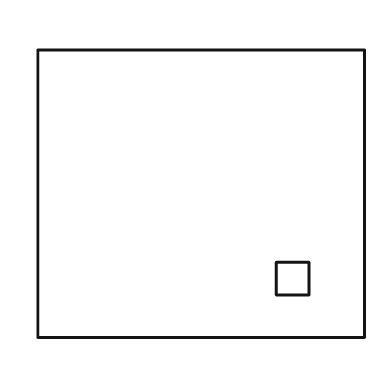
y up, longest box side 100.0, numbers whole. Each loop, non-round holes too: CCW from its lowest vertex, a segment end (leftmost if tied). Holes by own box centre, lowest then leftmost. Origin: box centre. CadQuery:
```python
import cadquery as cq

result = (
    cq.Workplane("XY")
    .moveTo(-50.0, -44.0)
    .lineTo(50.0, -44.0)
    .lineTo(50.0, 44.0)
    .lineTo(-50.0, 44.0)
    .close()
    .moveTo(23.0, -31.0)
    .lineTo(33.0, -31.0)
    .lineTo(33.0, -21.0)
    .lineTo(23.0, -21.0)
    .close()
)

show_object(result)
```